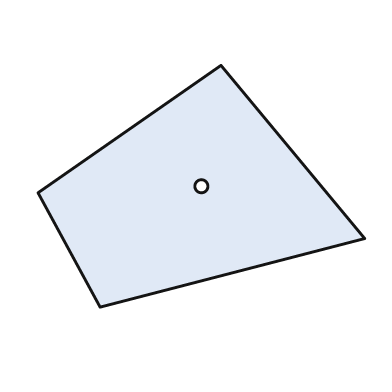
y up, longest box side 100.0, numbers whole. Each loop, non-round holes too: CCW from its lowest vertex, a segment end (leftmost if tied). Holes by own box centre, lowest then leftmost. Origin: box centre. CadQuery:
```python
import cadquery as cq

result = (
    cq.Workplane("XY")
    .moveTo(-31.0, -37.0)
    .lineTo(50.0, -16.0)
    .lineTo(6.0, 37.0)
    .lineTo(-50.0, -2.0)
    .close()
    .moveTo(0.0, 0.0)
    .circle(2.0)
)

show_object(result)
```